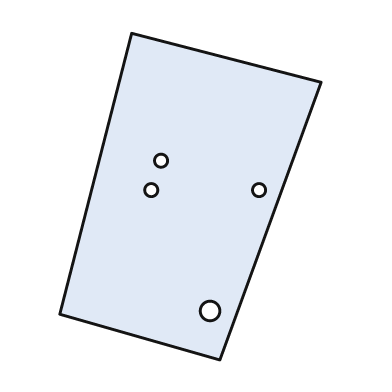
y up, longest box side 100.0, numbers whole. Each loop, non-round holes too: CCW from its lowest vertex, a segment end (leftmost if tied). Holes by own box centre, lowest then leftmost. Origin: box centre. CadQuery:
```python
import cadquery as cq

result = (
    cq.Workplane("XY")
    .moveTo(9.0, -50.0)
    .lineTo(40.0, 35.0)
    .lineTo(-18.0, 50.0)
    .lineTo(-40.0, -36.0)
    .close()
    .moveTo(6.0, -35.0)
    .circle(3.0)
    .moveTo(-12.0, 2.0)
    .circle(2.0)
    .moveTo(21.0, 2.0)
    .circle(2.0)
    .moveTo(-9.0, 11.0)
    .circle(2.0)
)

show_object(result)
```